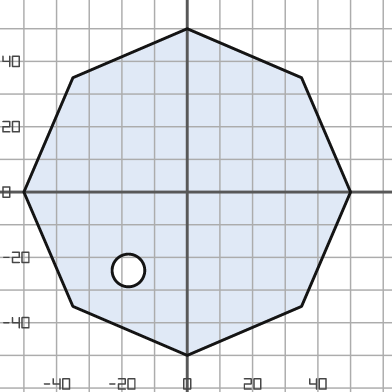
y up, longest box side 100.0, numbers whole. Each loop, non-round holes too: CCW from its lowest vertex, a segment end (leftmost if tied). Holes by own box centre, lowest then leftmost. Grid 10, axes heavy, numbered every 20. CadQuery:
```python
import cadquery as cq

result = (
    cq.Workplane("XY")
    .moveTo(0.0, -50.0)
    .lineTo(35.0, -35.0)
    .lineTo(50.0, 0.0)
    .lineTo(35.0, 35.0)
    .lineTo(0.0, 50.0)
    .lineTo(-35.0, 35.0)
    .lineTo(-50.0, 0.0)
    .lineTo(-35.0, -35.0)
    .close()
    .moveTo(-18.0, -24.0)
    .circle(5.0)
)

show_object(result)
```